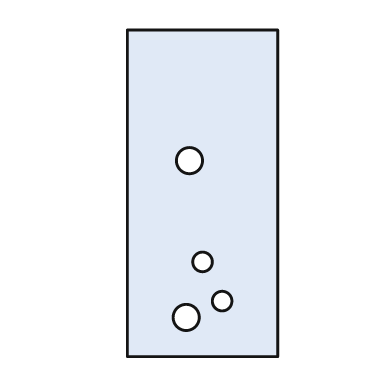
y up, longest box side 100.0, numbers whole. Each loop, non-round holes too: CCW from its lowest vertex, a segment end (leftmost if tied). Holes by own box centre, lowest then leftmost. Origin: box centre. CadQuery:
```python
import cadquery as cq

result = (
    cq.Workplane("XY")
    .moveTo(-23.0, -50.0)
    .lineTo(23.0, -50.0)
    .lineTo(23.0, 50.0)
    .lineTo(-23.0, 50.0)
    .close()
    .moveTo(-5.0, -38.0)
    .circle(4.0)
    .moveTo(6.0, -33.0)
    .circle(3.0)
    .moveTo(0.0, -21.0)
    .circle(3.0)
    .moveTo(-4.0, 10.0)
    .circle(4.0)
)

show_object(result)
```